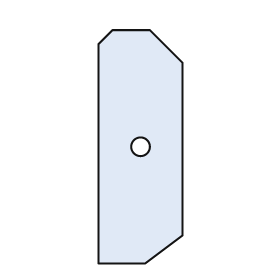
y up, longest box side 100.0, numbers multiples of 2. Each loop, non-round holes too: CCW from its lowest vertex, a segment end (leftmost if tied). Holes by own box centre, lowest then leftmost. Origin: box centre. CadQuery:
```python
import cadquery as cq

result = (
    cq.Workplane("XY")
    .moveTo(-18.0, -50.0)
    .lineTo(2.0, -50.0)
    .lineTo(18.0, -38.0)
    .lineTo(18.0, 36.0)
    .lineTo(4.0, 50.0)
    .lineTo(-12.0, 50.0)
    .lineTo(-18.0, 44.0)
    .close()
    .moveTo(0.0, 0.0)
    .circle(4.0)
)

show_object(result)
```